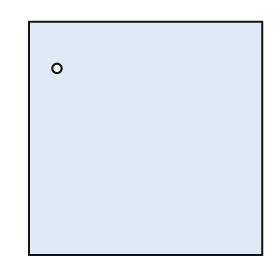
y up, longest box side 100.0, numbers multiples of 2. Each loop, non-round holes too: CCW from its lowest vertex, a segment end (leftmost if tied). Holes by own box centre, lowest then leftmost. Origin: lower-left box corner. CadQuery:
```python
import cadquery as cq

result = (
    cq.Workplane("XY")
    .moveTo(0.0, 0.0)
    .lineTo(100.0, 0.0)
    .lineTo(100.0, 100.0)
    .lineTo(0.0, 100.0)
    .close()
    .moveTo(12.0, 80.0)
    .circle(2.0)
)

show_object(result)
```